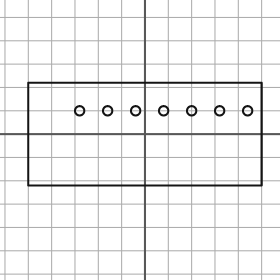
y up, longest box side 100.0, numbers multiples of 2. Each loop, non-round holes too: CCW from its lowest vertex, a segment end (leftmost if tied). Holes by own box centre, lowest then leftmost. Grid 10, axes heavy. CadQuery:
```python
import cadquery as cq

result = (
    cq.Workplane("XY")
    .moveTo(-50.0, -22.0)
    .lineTo(50.0, -22.0)
    .lineTo(50.0, 22.0)
    .lineTo(-50.0, 22.0)
    .close()
    .moveTo(-28.0, 10.0)
    .circle(2.0)
    .moveTo(-16.0, 10.0)
    .circle(2.0)
    .moveTo(-4.0, 10.0)
    .circle(2.0)
    .moveTo(8.0, 10.0)
    .circle(2.0)
    .moveTo(20.0, 10.0)
    .circle(2.0)
    .moveTo(32.0, 10.0)
    .circle(2.0)
    .moveTo(44.0, 10.0)
    .circle(2.0)
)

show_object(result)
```